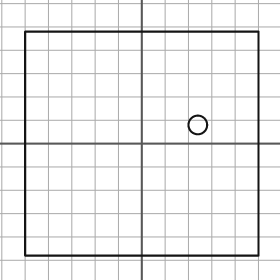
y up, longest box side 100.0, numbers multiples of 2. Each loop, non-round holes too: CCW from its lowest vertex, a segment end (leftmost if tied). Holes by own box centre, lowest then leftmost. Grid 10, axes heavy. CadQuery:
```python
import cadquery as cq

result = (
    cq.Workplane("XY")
    .moveTo(-50.0, -48.0)
    .lineTo(50.0, -48.0)
    .lineTo(50.0, 48.0)
    .lineTo(-50.0, 48.0)
    .close()
    .moveTo(24.0, 8.0)
    .circle(4.0)
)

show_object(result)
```